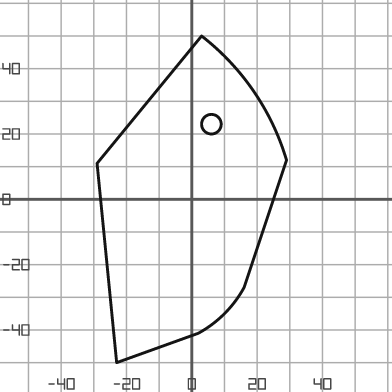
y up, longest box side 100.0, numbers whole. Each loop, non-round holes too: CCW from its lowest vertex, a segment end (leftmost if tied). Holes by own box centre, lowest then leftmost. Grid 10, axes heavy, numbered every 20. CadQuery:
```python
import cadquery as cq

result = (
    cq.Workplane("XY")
    .moveTo(-23.0, -50.0)
    .lineTo(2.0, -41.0)
    .threePointArc((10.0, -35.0), (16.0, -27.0))
    .lineTo(29.0, 12.0)
    .threePointArc((19.0, 33.0), (3.0, 50.0))
    .lineTo(-29.0, 11.0)
    .close()
    .moveTo(6.0, 23.0)
    .circle(3.0)
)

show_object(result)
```